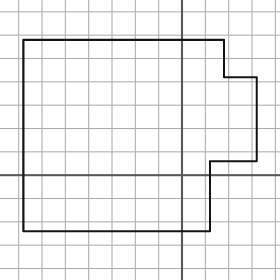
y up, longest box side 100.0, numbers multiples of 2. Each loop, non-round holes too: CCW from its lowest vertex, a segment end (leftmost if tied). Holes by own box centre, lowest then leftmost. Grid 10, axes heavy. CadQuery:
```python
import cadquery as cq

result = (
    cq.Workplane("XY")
    .moveTo(-68.0, -24.0)
    .lineTo(12.0, -24.0)
    .lineTo(12.0, 6.0)
    .lineTo(32.0, 6.0)
    .lineTo(32.0, 42.0)
    .lineTo(18.0, 42.0)
    .lineTo(18.0, 58.0)
    .lineTo(-68.0, 58.0)
    .close()
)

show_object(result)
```